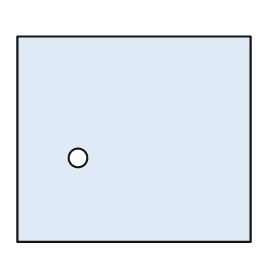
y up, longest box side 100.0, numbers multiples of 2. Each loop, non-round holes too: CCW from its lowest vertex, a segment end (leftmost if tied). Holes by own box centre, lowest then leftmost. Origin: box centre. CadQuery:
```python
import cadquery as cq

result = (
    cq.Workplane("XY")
    .moveTo(-50.0, -44.0)
    .lineTo(50.0, -44.0)
    .lineTo(50.0, 44.0)
    .lineTo(-50.0, 44.0)
    .close()
    .moveTo(-24.0, -8.0)
    .circle(4.0)
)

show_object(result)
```